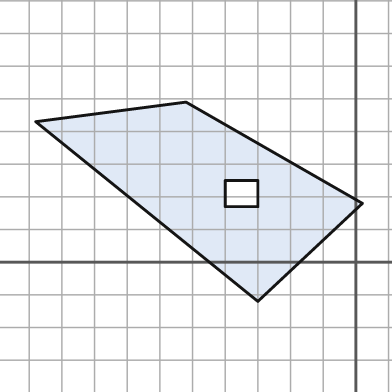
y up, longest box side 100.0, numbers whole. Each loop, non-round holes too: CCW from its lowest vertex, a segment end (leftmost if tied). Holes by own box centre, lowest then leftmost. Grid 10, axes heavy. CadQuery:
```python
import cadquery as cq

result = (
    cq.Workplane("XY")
    .moveTo(-30.0, -12.0)
    .lineTo(2.0, 18.0)
    .lineTo(-52.0, 49.0)
    .lineTo(-98.0, 43.0)
    .close()
    .moveTo(-40.0, 17.0)
    .lineTo(-30.0, 17.0)
    .lineTo(-30.0, 25.0)
    .lineTo(-40.0, 25.0)
    .close()
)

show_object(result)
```